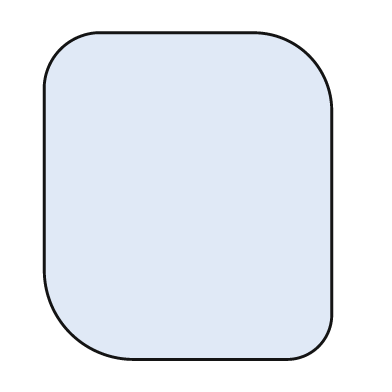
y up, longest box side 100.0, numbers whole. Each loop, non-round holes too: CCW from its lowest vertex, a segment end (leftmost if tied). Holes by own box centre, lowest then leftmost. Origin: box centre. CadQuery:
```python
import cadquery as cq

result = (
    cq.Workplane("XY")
    .moveTo(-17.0, -50.0)
    .lineTo(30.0, -50.0)
    .threePointArc((40.0, -46.0), (44.0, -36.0))
    .lineTo(44.0, 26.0)
    .threePointArc((37.0, 43.0), (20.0, 50.0))
    .lineTo(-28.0, 50.0)
    .threePointArc((-39.0, 45.0), (-44.0, 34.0))
    .lineTo(-44.0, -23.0)
    .threePointArc((-36.0, -42.0), (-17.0, -50.0))
    .close()
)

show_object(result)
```